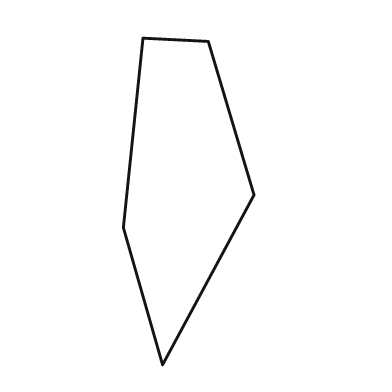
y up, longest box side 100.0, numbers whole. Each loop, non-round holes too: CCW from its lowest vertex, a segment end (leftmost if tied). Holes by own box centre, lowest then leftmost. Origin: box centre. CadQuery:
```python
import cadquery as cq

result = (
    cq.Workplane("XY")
    .moveTo(-8.0, -50.0)
    .lineTo(20.0, 2.0)
    .lineTo(6.0, 49.0)
    .lineTo(-14.0, 50.0)
    .lineTo(-20.0, -8.0)
    .close()
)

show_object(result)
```